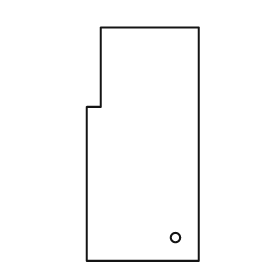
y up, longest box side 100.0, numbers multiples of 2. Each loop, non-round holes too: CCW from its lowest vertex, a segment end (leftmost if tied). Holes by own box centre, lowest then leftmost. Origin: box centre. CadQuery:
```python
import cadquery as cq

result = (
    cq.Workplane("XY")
    .moveTo(-24.0, -50.0)
    .lineTo(24.0, -50.0)
    .lineTo(24.0, 50.0)
    .lineTo(-18.0, 50.0)
    .lineTo(-18.0, 16.0)
    .lineTo(-24.0, 16.0)
    .close()
    .moveTo(14.0, -40.0)
    .circle(2.0)
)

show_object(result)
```